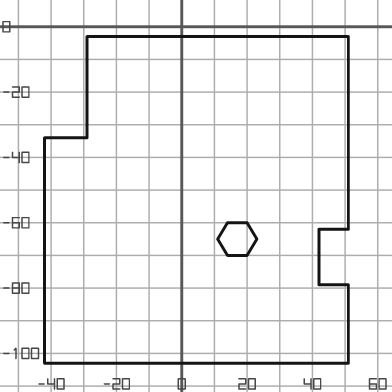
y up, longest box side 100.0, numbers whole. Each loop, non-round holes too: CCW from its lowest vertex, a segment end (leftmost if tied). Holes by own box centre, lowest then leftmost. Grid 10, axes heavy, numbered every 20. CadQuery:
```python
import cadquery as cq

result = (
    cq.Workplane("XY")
    .moveTo(-42.0, -103.0)
    .lineTo(51.0, -103.0)
    .lineTo(51.0, -79.0)
    .lineTo(42.0, -79.0)
    .lineTo(42.0, -62.0)
    .lineTo(51.0, -62.0)
    .lineTo(51.0, -3.0)
    .lineTo(-29.0, -3.0)
    .lineTo(-29.0, -34.0)
    .lineTo(-42.0, -34.0)
    .close()
    .moveTo(14.0, -70.0)
    .lineTo(20.0, -70.0)
    .lineTo(23.0, -65.0)
    .lineTo(20.0, -60.0)
    .lineTo(14.0, -60.0)
    .lineTo(11.0, -65.0)
    .close()
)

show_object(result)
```